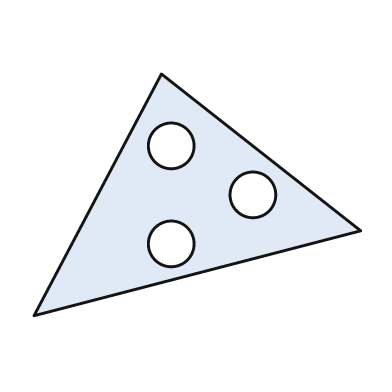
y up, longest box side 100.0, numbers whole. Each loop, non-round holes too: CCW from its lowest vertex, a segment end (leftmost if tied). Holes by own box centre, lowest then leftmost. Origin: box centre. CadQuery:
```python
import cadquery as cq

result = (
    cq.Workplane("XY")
    .moveTo(-50.0, -37.0)
    .lineTo(50.0, -11.0)
    .lineTo(-11.0, 37.0)
    .close()
    .moveTo(-8.0, -15.0)
    .circle(7.0)
    .moveTo(17.0, 0.0)
    .circle(7.0)
    .moveTo(-8.0, 15.0)
    .circle(7.0)
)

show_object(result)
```